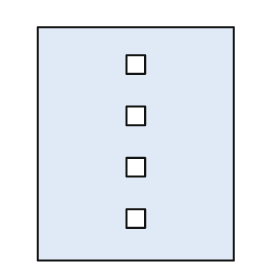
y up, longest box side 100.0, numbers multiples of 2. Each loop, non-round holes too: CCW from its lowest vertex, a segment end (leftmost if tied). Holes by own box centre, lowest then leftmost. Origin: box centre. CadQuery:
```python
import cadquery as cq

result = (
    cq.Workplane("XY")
    .moveTo(-42.0, -50.0)
    .lineTo(42.0, -50.0)
    .lineTo(42.0, 50.0)
    .lineTo(-42.0, 50.0)
    .close()
    .moveTo(-4.0, -36.0)
    .lineTo(4.0, -36.0)
    .lineTo(4.0, -28.0)
    .lineTo(-4.0, -28.0)
    .close()
    .moveTo(-4.0, -14.0)
    .lineTo(4.0, -14.0)
    .lineTo(4.0, -6.0)
    .lineTo(-4.0, -6.0)
    .close()
    .moveTo(-4.0, 8.0)
    .lineTo(4.0, 8.0)
    .lineTo(4.0, 16.0)
    .lineTo(-4.0, 16.0)
    .close()
    .moveTo(-4.0, 30.0)
    .lineTo(4.0, 30.0)
    .lineTo(4.0, 38.0)
    .lineTo(-4.0, 38.0)
    .close()
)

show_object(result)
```